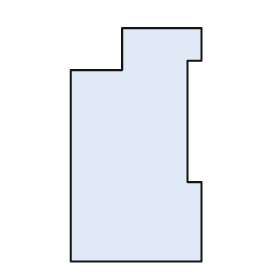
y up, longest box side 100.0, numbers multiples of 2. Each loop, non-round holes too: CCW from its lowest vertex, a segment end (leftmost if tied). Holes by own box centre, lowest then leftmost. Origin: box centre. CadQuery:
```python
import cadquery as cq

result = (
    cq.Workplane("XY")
    .moveTo(-28.0, -50.0)
    .lineTo(28.0, -50.0)
    .lineTo(28.0, -16.0)
    .lineTo(22.0, -16.0)
    .lineTo(22.0, 36.0)
    .lineTo(28.0, 36.0)
    .lineTo(28.0, 50.0)
    .lineTo(-6.0, 50.0)
    .lineTo(-6.0, 32.0)
    .lineTo(-28.0, 32.0)
    .close()
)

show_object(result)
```